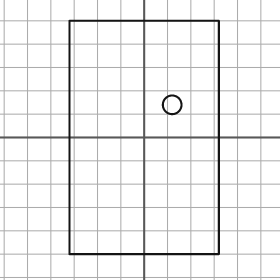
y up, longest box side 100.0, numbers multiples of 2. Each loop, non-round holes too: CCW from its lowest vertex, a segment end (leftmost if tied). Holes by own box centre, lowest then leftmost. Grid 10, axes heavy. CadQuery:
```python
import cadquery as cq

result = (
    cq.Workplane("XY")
    .moveTo(-32.0, -50.0)
    .lineTo(32.0, -50.0)
    .lineTo(32.0, 50.0)
    .lineTo(-32.0, 50.0)
    .close()
    .moveTo(12.0, 14.0)
    .circle(4.0)
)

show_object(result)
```